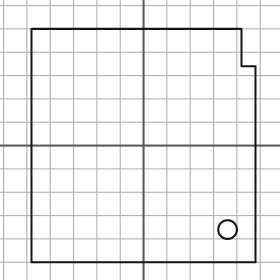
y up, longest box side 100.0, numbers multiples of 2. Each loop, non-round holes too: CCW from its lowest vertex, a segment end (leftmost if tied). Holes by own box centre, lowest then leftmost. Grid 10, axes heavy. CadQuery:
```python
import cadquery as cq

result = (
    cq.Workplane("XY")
    .moveTo(-48.0, -50.0)
    .lineTo(48.0, -50.0)
    .lineTo(48.0, 34.0)
    .lineTo(42.0, 34.0)
    .lineTo(42.0, 50.0)
    .lineTo(-48.0, 50.0)
    .close()
    .moveTo(36.0, -36.0)
    .circle(4.0)
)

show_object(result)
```